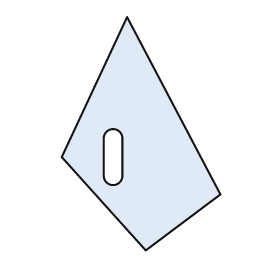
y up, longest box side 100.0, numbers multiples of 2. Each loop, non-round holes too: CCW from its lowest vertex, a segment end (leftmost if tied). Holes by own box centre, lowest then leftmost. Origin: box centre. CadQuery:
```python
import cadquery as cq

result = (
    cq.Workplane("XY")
    .moveTo(2.0, -50.0)
    .lineTo(34.0, -26.0)
    .lineTo(-6.0, 50.0)
    .lineTo(-34.0, -10.0)
    .close()
    .moveTo(-16.0, -18.0)
    .threePointArc((-12.0, -22.0), (-8.0, -18.0))
    .lineTo(-8.0, -2.0)
    .threePointArc((-12.0, 2.0), (-16.0, -2.0))
    .close()
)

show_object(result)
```